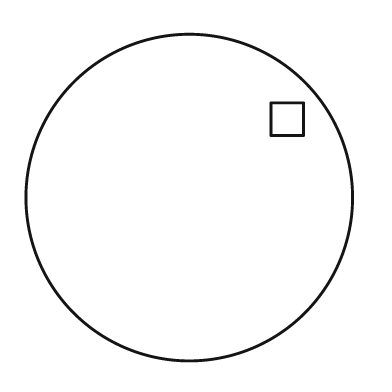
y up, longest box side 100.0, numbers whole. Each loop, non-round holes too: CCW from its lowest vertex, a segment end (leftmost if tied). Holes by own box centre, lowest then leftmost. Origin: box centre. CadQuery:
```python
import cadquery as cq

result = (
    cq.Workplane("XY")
    .moveTo(0.0, 0.0)
    .circle(50.0)
    .moveTo(25.0, 19.0)
    .lineTo(35.0, 19.0)
    .lineTo(35.0, 29.0)
    .lineTo(25.0, 29.0)
    .close()
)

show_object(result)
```